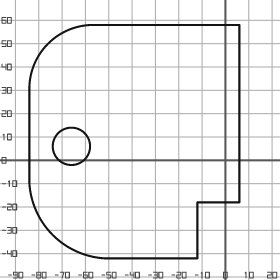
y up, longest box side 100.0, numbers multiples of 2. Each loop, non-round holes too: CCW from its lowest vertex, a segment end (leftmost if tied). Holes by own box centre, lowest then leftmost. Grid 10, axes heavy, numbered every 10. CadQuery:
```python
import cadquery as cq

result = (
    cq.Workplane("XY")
    .moveTo(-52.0, -42.0)
    .lineTo(-12.0, -42.0)
    .lineTo(-12.0, -18.0)
    .lineTo(6.0, -18.0)
    .lineTo(6.0, 58.0)
    .lineTo(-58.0, 58.0)
    .threePointArc((-76.0, 50.0), (-84.0, 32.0))
    .lineTo(-84.0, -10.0)
    .threePointArc((-74.0, -32.0), (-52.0, -42.0))
    .close()
    .moveTo(-66.0, 6.0)
    .circle(8.0)
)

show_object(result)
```